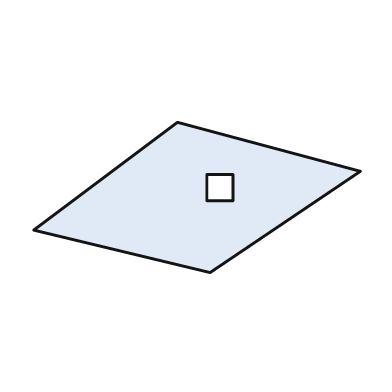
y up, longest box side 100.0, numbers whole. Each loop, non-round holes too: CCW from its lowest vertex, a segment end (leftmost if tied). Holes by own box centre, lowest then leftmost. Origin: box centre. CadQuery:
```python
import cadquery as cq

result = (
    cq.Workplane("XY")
    .moveTo(4.0, -23.0)
    .lineTo(50.0, 8.0)
    .lineTo(-6.0, 23.0)
    .lineTo(-50.0, -10.0)
    .close()
    .moveTo(3.0, -1.0)
    .lineTo(11.0, -1.0)
    .lineTo(11.0, 7.0)
    .lineTo(3.0, 7.0)
    .close()
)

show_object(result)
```